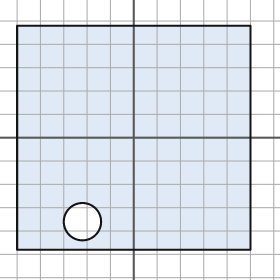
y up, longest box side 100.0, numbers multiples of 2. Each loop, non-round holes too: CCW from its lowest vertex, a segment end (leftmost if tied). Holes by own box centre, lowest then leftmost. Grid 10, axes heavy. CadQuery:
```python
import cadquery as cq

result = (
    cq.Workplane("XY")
    .moveTo(-50.0, -48.0)
    .lineTo(50.0, -48.0)
    .lineTo(50.0, 48.0)
    .lineTo(-50.0, 48.0)
    .close()
    .moveTo(-22.0, -36.0)
    .circle(8.0)
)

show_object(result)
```